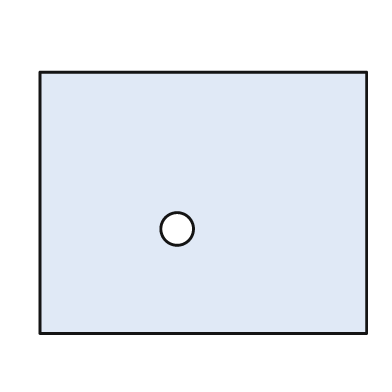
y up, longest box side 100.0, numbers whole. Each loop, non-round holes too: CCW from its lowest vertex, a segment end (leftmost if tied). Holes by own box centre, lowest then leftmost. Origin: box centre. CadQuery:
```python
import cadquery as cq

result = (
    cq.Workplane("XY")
    .moveTo(-50.0, -40.0)
    .lineTo(50.0, -40.0)
    .lineTo(50.0, 40.0)
    .lineTo(-50.0, 40.0)
    .close()
    .moveTo(-8.0, -8.0)
    .circle(5.0)
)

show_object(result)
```